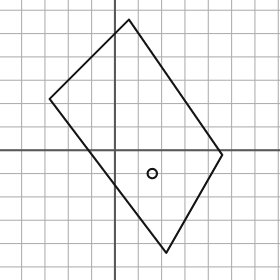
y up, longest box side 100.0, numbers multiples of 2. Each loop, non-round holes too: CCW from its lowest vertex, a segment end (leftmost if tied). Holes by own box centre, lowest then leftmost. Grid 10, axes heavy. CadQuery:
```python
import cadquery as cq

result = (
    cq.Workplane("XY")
    .moveTo(22.0, -44.0)
    .lineTo(46.0, -2.0)
    .lineTo(6.0, 56.0)
    .lineTo(-28.0, 22.0)
    .close()
    .moveTo(16.0, -10.0)
    .circle(2.0)
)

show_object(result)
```